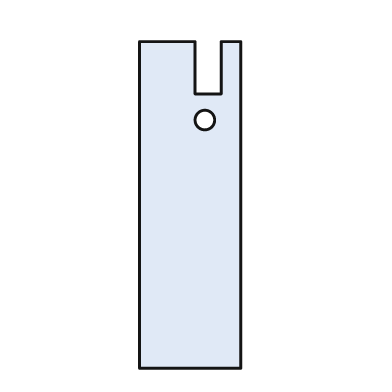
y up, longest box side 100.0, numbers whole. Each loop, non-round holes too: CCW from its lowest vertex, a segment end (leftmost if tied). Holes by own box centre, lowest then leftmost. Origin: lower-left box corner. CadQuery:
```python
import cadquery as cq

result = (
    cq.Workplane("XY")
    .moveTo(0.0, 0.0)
    .lineTo(31.0, 0.0)
    .lineTo(31.0, 100.0)
    .lineTo(25.0, 100.0)
    .lineTo(25.0, 84.0)
    .lineTo(17.0, 84.0)
    .lineTo(17.0, 100.0)
    .lineTo(0.0, 100.0)
    .close()
    .moveTo(20.0, 76.0)
    .circle(3.0)
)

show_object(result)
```